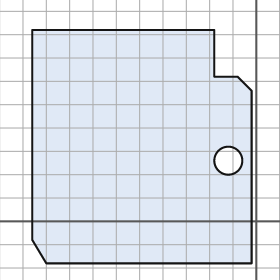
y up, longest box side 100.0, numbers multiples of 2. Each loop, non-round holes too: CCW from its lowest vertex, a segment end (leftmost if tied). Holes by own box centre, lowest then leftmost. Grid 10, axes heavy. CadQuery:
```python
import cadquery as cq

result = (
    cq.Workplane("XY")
    .moveTo(-90.0, -18.0)
    .lineTo(-2.0, -18.0)
    .lineTo(-2.0, 56.0)
    .lineTo(-8.0, 62.0)
    .lineTo(-18.0, 62.0)
    .lineTo(-18.0, 82.0)
    .lineTo(-96.0, 82.0)
    .lineTo(-96.0, -8.0)
    .close()
    .moveTo(-12.0, 26.0)
    .circle(6.0)
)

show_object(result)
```